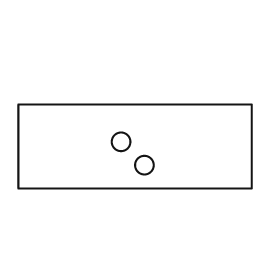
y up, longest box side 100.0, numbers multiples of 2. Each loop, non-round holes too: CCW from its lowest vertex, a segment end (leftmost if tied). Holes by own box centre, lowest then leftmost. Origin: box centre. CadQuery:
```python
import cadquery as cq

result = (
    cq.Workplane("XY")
    .moveTo(-50.0, -18.0)
    .lineTo(50.0, -18.0)
    .lineTo(50.0, 18.0)
    .lineTo(-50.0, 18.0)
    .close()
    .moveTo(4.0, -8.0)
    .circle(4.0)
    .moveTo(-6.0, 2.0)
    .circle(4.0)
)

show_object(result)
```